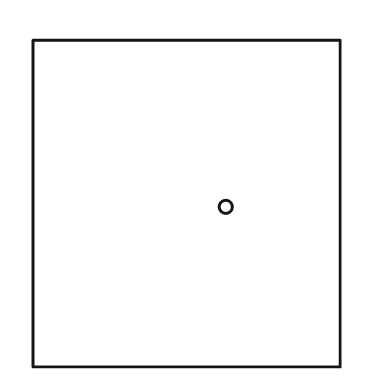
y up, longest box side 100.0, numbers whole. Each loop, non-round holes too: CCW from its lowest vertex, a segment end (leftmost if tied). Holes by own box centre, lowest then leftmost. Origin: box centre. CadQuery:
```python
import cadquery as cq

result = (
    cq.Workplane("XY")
    .moveTo(-47.0, -50.0)
    .lineTo(47.0, -50.0)
    .lineTo(47.0, 50.0)
    .lineTo(-47.0, 50.0)
    .close()
    .moveTo(12.0, -1.0)
    .circle(2.0)
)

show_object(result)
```